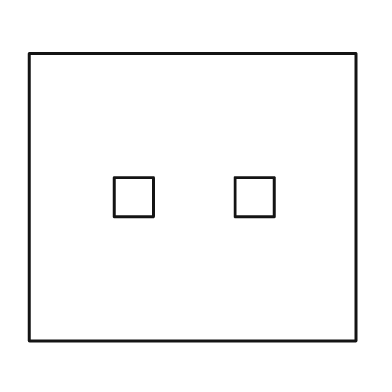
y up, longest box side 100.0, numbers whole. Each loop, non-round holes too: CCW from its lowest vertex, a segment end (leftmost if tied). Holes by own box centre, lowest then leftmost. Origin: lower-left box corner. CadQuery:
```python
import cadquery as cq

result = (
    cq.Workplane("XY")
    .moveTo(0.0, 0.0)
    .lineTo(100.0, 0.0)
    .lineTo(100.0, 88.0)
    .lineTo(0.0, 88.0)
    .close()
    .moveTo(26.0, 38.0)
    .lineTo(38.0, 38.0)
    .lineTo(38.0, 50.0)
    .lineTo(26.0, 50.0)
    .close()
    .moveTo(63.0, 38.0)
    .lineTo(75.0, 38.0)
    .lineTo(75.0, 50.0)
    .lineTo(63.0, 50.0)
    .close()
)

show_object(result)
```